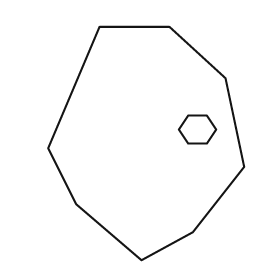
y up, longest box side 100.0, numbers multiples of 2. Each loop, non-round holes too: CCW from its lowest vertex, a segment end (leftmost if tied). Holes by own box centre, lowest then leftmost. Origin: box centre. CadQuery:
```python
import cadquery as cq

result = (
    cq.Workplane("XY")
    .moveTo(-2.0, -50.0)
    .lineTo(20.0, -38.0)
    .lineTo(42.0, -10.0)
    .lineTo(34.0, 28.0)
    .lineTo(10.0, 50.0)
    .lineTo(-20.0, 50.0)
    .lineTo(-42.0, -2.0)
    .lineTo(-30.0, -26.0)
    .close()
    .moveTo(18.0, 0.0)
    .lineTo(26.0, 0.0)
    .lineTo(30.0, 6.0)
    .lineTo(26.0, 12.0)
    .lineTo(18.0, 12.0)
    .lineTo(14.0, 6.0)
    .close()
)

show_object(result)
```